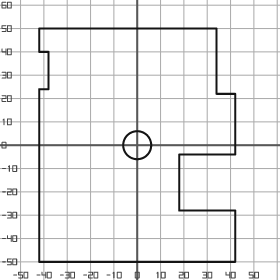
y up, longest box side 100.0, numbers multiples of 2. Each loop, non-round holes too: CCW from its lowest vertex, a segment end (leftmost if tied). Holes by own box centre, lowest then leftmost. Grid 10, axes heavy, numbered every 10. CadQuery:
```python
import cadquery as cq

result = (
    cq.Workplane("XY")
    .moveTo(-42.0, -50.0)
    .lineTo(42.0, -50.0)
    .lineTo(42.0, -28.0)
    .lineTo(18.0, -28.0)
    .lineTo(18.0, -4.0)
    .lineTo(42.0, -4.0)
    .lineTo(42.0, 22.0)
    .lineTo(34.0, 22.0)
    .lineTo(34.0, 50.0)
    .lineTo(-42.0, 50.0)
    .lineTo(-42.0, 40.0)
    .lineTo(-38.0, 40.0)
    .lineTo(-38.0, 24.0)
    .lineTo(-42.0, 24.0)
    .close()
    .moveTo(0.0, 0.0)
    .circle(6.0)
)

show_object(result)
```